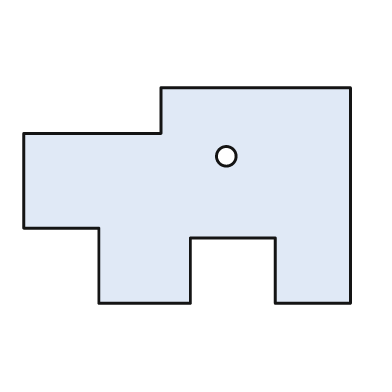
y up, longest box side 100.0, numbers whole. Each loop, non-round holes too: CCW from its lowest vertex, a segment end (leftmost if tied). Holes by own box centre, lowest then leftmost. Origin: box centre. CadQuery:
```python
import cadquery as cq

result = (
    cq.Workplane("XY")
    .moveTo(-27.0, -33.0)
    .lineTo(1.0, -33.0)
    .lineTo(1.0, -13.0)
    .lineTo(27.0, -13.0)
    .lineTo(27.0, -33.0)
    .lineTo(50.0, -33.0)
    .lineTo(50.0, 33.0)
    .lineTo(-8.0, 33.0)
    .lineTo(-8.0, 19.0)
    .lineTo(-50.0, 19.0)
    .lineTo(-50.0, -10.0)
    .lineTo(-27.0, -10.0)
    .close()
    .moveTo(12.0, 12.0)
    .circle(3.0)
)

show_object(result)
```